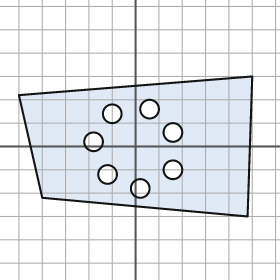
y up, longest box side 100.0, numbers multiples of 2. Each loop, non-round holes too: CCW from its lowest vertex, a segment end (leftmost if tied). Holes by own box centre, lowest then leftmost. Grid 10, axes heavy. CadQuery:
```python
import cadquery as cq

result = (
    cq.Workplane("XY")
    .moveTo(48.0, -30.0)
    .lineTo(50.0, 30.0)
    .lineTo(-50.0, 22.0)
    .lineTo(-40.0, -22.0)
    .close()
    .moveTo(2.0, -18.0)
    .circle(4.0)
    .moveTo(-12.0, -12.0)
    .circle(4.0)
    .moveTo(16.0, -10.0)
    .circle(4.0)
    .moveTo(-18.0, 2.0)
    .circle(4.0)
    .moveTo(16.0, 6.0)
    .circle(4.0)
    .moveTo(-10.0, 14.0)
    .circle(4.0)
    .moveTo(6.0, 16.0)
    .circle(4.0)
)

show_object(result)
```